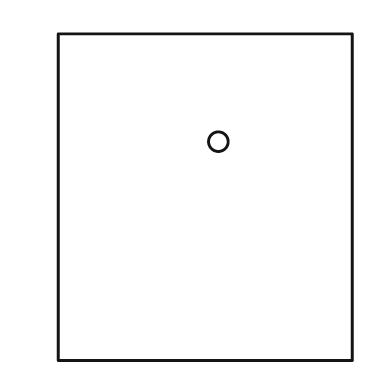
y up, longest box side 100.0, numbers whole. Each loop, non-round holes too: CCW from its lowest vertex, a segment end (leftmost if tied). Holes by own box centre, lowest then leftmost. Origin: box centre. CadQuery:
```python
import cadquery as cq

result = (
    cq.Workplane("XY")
    .moveTo(-45.0, -50.0)
    .lineTo(45.0, -50.0)
    .lineTo(45.0, 50.0)
    .lineTo(-45.0, 50.0)
    .close()
    .moveTo(4.0, 17.0)
    .circle(3.0)
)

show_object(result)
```